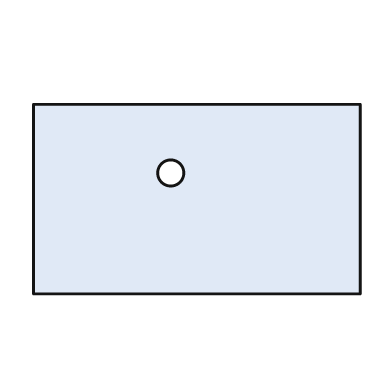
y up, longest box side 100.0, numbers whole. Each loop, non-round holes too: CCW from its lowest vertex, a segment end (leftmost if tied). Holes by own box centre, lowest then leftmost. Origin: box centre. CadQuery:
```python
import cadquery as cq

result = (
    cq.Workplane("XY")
    .moveTo(-50.0, -29.0)
    .lineTo(50.0, -29.0)
    .lineTo(50.0, 29.0)
    .lineTo(-50.0, 29.0)
    .close()
    .moveTo(-8.0, 8.0)
    .circle(4.0)
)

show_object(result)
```